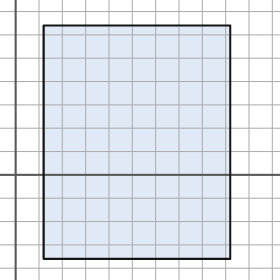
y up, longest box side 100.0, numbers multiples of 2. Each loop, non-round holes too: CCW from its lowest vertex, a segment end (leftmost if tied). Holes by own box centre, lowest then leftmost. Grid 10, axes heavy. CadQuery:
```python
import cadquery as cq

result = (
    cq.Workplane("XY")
    .moveTo(12.0, -36.0)
    .lineTo(92.0, -36.0)
    .lineTo(92.0, 64.0)
    .lineTo(12.0, 64.0)
    .close()
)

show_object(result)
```